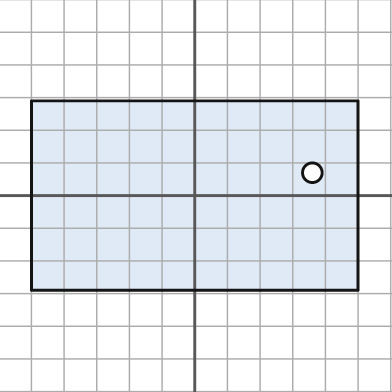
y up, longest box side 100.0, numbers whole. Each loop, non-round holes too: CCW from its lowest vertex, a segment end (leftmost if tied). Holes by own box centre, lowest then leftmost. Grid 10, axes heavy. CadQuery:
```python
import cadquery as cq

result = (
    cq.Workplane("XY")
    .moveTo(-50.0, -29.0)
    .lineTo(50.0, -29.0)
    .lineTo(50.0, 29.0)
    .lineTo(-50.0, 29.0)
    .close()
    .moveTo(36.0, 7.0)
    .circle(3.0)
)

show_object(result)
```